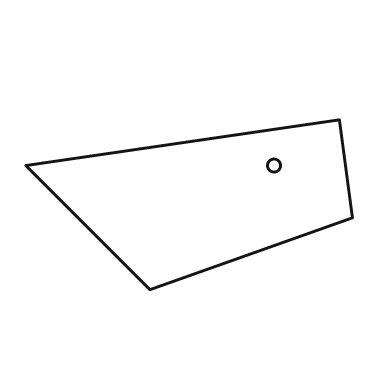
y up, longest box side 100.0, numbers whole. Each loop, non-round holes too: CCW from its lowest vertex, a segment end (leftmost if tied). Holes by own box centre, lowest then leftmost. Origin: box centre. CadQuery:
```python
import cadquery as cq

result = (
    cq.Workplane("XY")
    .moveTo(-12.0, -26.0)
    .lineTo(50.0, -4.0)
    .lineTo(46.0, 26.0)
    .lineTo(-50.0, 12.0)
    .close()
    .moveTo(26.0, 12.0)
    .circle(2.0)
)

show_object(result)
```